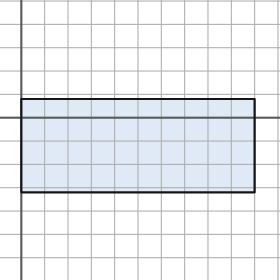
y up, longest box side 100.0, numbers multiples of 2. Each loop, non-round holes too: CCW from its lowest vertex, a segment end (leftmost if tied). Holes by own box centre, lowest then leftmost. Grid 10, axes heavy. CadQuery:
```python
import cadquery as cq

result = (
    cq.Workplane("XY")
    .moveTo(0.0, -32.0)
    .lineTo(100.0, -32.0)
    .lineTo(100.0, 8.0)
    .lineTo(0.0, 8.0)
    .close()
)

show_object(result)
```